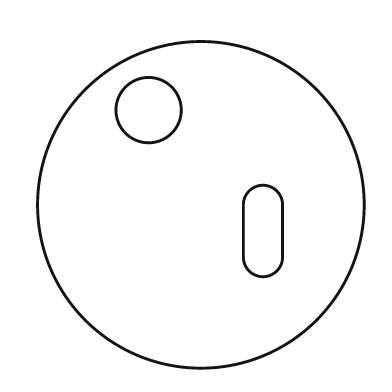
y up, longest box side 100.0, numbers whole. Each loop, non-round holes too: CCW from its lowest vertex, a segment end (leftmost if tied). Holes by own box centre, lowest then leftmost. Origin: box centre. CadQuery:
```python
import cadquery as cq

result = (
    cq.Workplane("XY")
    .moveTo(0.0, 0.0)
    .circle(50.0)
    .moveTo(13.0, -16.0)
    .threePointArc((19.0, -22.0), (25.0, -16.0))
    .lineTo(25.0, 0.0)
    .threePointArc((19.0, 6.0), (13.0, 0.0))
    .close()
    .moveTo(-16.0, 29.0)
    .circle(10.0)
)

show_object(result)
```